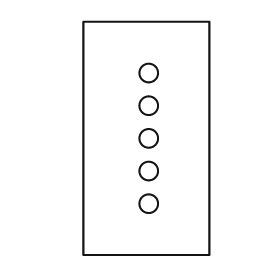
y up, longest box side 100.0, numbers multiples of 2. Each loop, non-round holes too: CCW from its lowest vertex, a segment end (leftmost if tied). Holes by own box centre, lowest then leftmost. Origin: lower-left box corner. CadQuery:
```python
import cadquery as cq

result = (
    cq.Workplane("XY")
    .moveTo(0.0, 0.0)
    .lineTo(54.0, 0.0)
    .lineTo(54.0, 100.0)
    .lineTo(0.0, 100.0)
    .close()
    .moveTo(28.0, 22.0)
    .circle(4.0)
    .moveTo(28.0, 36.0)
    .circle(4.0)
    .moveTo(28.0, 50.0)
    .circle(4.0)
    .moveTo(28.0, 64.0)
    .circle(4.0)
    .moveTo(28.0, 78.0)
    .circle(4.0)
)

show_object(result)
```